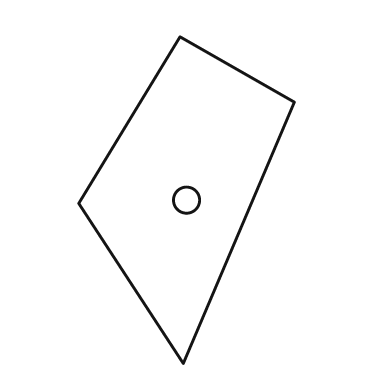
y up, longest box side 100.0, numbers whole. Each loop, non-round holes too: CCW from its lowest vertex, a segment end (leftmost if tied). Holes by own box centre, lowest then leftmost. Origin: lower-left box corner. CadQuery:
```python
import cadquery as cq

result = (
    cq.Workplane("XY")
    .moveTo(32.0, 0.0)
    .lineTo(66.0, 80.0)
    .lineTo(31.0, 100.0)
    .lineTo(0.0, 49.0)
    .close()
    .moveTo(33.0, 50.0)
    .circle(4.0)
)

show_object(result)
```